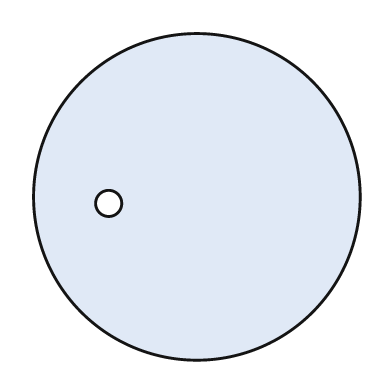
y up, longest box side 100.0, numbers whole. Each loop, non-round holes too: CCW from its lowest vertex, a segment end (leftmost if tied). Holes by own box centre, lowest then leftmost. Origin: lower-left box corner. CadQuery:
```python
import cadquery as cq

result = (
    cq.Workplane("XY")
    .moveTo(50.0, 50.0)
    .circle(50.0)
    .moveTo(23.0, 48.0)
    .circle(4.0)
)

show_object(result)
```